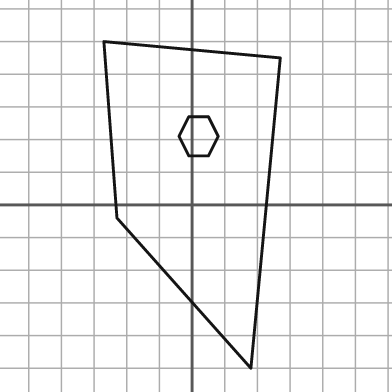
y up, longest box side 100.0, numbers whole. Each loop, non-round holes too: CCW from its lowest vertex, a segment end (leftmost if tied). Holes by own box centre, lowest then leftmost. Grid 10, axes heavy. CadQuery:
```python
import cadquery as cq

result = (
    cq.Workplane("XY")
    .moveTo(18.0, -50.0)
    .lineTo(27.0, 45.0)
    .lineTo(-27.0, 50.0)
    .lineTo(-23.0, -4.0)
    .close()
    .moveTo(-1.0, 15.0)
    .lineTo(5.0, 15.0)
    .lineTo(8.0, 21.0)
    .lineTo(5.0, 27.0)
    .lineTo(-1.0, 27.0)
    .lineTo(-4.0, 21.0)
    .close()
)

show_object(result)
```